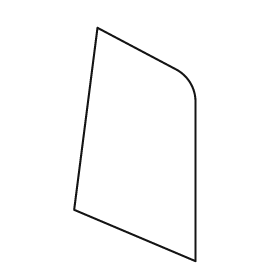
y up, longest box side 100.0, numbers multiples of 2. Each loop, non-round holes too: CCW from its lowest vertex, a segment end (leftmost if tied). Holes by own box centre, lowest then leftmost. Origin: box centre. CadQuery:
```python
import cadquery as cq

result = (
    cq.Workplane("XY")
    .moveTo(26.0, -50.0)
    .lineTo(26.0, 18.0)
    .threePointArc((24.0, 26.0), (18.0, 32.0))
    .lineTo(-16.0, 50.0)
    .lineTo(-26.0, -28.0)
    .close()
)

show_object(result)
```